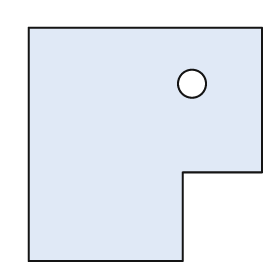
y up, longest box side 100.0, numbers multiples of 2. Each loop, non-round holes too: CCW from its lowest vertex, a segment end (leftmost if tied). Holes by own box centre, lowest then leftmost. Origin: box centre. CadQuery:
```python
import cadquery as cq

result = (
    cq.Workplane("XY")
    .moveTo(-50.0, -50.0)
    .lineTo(16.0, -50.0)
    .lineTo(16.0, -12.0)
    .lineTo(50.0, -12.0)
    .lineTo(50.0, 50.0)
    .lineTo(-50.0, 50.0)
    .close()
    .moveTo(20.0, 26.0)
    .circle(6.0)
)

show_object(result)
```